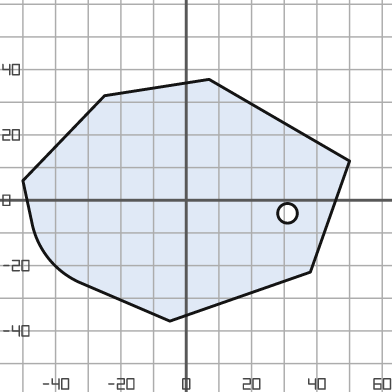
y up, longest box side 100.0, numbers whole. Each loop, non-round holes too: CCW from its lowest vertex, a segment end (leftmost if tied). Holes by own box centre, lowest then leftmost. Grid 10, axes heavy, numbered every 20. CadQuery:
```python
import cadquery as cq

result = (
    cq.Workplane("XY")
    .moveTo(-5.0, -37.0)
    .lineTo(38.0, -22.0)
    .lineTo(50.0, 12.0)
    .lineTo(7.0, 37.0)
    .lineTo(-25.0, 32.0)
    .lineTo(-50.0, 6.0)
    .lineTo(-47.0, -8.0)
    .threePointArc((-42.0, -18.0), (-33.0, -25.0))
    .close()
    .moveTo(31.0, -4.0)
    .circle(3.0)
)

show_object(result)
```